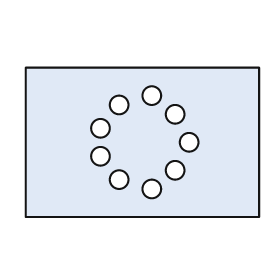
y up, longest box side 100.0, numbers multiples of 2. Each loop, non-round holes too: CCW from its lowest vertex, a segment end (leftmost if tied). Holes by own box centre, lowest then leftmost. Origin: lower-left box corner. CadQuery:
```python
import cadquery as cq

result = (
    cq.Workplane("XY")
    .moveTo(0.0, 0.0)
    .lineTo(100.0, 0.0)
    .lineTo(100.0, 64.0)
    .lineTo(0.0, 64.0)
    .close()
    .moveTo(54.0, 12.0)
    .circle(4.0)
    .moveTo(40.0, 16.0)
    .circle(4.0)
    .moveTo(64.0, 20.0)
    .circle(4.0)
    .moveTo(32.0, 26.0)
    .circle(4.0)
    .moveTo(70.0, 32.0)
    .circle(4.0)
    .moveTo(32.0, 38.0)
    .circle(4.0)
    .moveTo(64.0, 44.0)
    .circle(4.0)
    .moveTo(40.0, 48.0)
    .circle(4.0)
    .moveTo(54.0, 52.0)
    .circle(4.0)
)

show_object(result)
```